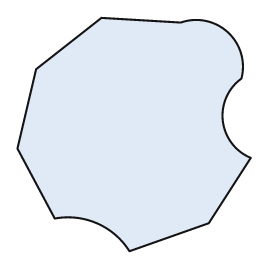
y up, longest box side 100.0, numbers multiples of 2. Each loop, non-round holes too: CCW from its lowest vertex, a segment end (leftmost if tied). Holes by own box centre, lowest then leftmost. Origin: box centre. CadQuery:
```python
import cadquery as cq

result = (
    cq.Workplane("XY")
    .moveTo(-2.0, -50.0)
    .lineTo(32.0, -38.0)
    .lineTo(50.0, -10.0)
    .threePointArc((38.0, 6.0), (46.0, 24.0))
    .threePointArc((40.0, 44.0), (20.0, 48.0))
    .lineTo(-14.0, 50.0)
    .lineTo(-42.0, 28.0)
    .lineTo(-50.0, -6.0)
    .lineTo(-34.0, -36.0)
    .threePointArc((-16.0, -38.0), (-2.0, -50.0))
    .close()
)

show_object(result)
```